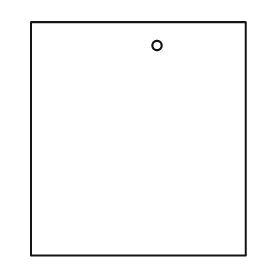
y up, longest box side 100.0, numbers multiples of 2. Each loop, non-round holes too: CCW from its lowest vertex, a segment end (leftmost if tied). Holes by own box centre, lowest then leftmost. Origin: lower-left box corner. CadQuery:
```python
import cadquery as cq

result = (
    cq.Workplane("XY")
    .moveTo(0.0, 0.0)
    .lineTo(92.0, 0.0)
    .lineTo(92.0, 100.0)
    .lineTo(0.0, 100.0)
    .close()
    .moveTo(54.0, 90.0)
    .circle(2.0)
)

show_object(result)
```